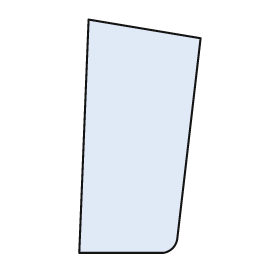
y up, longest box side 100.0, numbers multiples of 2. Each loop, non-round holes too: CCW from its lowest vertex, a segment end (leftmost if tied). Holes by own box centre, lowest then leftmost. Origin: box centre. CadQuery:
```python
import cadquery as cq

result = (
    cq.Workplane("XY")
    .moveTo(-26.0, -50.0)
    .lineTo(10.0, -50.0)
    .threePointArc((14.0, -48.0), (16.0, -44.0))
    .lineTo(26.0, 42.0)
    .lineTo(-22.0, 50.0)
    .close()
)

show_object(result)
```